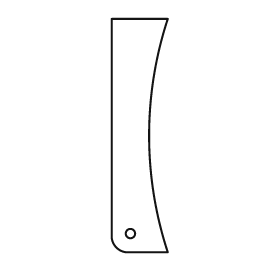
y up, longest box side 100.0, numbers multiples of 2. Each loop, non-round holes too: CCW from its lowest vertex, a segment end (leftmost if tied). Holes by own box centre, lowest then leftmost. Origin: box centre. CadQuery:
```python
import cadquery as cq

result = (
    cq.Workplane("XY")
    .moveTo(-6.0, -50.0)
    .lineTo(12.0, -50.0)
    .threePointArc((4.0, 0.0), (12.0, 50.0))
    .lineTo(-12.0, 50.0)
    .lineTo(-12.0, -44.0)
    .threePointArc((-10.0, -48.0), (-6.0, -50.0))
    .close()
    .moveTo(-4.0, -42.0)
    .circle(2.0)
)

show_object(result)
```